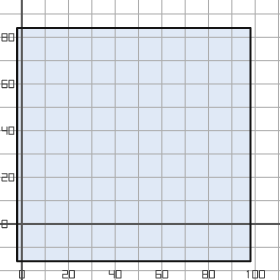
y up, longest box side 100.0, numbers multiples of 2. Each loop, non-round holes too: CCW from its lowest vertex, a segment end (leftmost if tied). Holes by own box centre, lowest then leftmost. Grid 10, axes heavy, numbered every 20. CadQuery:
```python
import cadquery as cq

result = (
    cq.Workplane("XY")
    .moveTo(-2.0, -16.0)
    .lineTo(98.0, -16.0)
    .lineTo(98.0, 84.0)
    .lineTo(-2.0, 84.0)
    .close()
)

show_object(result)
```